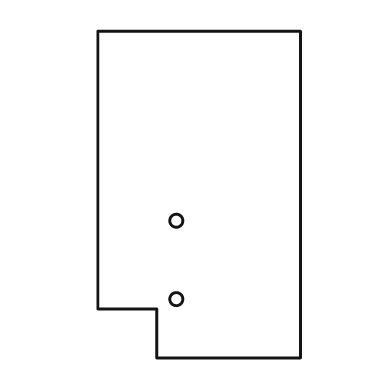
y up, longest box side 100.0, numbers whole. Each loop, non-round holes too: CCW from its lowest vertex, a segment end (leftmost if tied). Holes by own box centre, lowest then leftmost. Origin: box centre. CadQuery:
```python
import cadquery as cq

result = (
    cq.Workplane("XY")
    .moveTo(-13.0, -50.0)
    .lineTo(31.0, -50.0)
    .lineTo(31.0, 50.0)
    .lineTo(-31.0, 50.0)
    .lineTo(-31.0, -35.0)
    .lineTo(-13.0, -35.0)
    .close()
    .moveTo(-7.0, -32.0)
    .circle(2.0)
    .moveTo(-7.0, -8.0)
    .circle(2.0)
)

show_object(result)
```